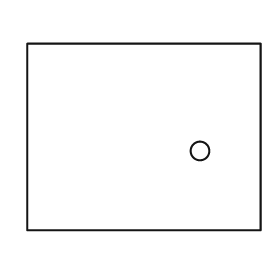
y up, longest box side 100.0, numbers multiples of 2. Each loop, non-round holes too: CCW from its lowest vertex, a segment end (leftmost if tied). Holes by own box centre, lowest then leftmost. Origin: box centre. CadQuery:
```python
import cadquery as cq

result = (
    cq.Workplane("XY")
    .moveTo(-50.0, -40.0)
    .lineTo(50.0, -40.0)
    .lineTo(50.0, 40.0)
    .lineTo(-50.0, 40.0)
    .close()
    .moveTo(24.0, -6.0)
    .circle(4.0)
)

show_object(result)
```